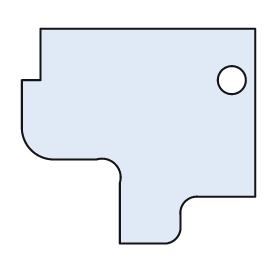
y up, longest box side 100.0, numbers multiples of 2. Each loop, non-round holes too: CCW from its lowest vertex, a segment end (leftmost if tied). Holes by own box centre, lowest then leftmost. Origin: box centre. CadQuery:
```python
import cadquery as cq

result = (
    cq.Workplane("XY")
    .moveTo(-8.0, -46.0)
    .lineTo(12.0, -46.0)
    .threePointArc((16.0, -44.0), (18.0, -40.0))
    .lineTo(18.0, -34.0)
    .threePointArc((20.0, -28.0), (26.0, -26.0))
    .lineTo(50.0, -26.0)
    .lineTo(50.0, 46.0)
    .lineTo(-42.0, 46.0)
    .lineTo(-42.0, 24.0)
    .lineTo(-50.0, 24.0)
    .lineTo(-50.0, 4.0)
    .threePointArc((-46.0, -6.0), (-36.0, -10.0))
    .lineTo(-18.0, -10.0)
    .threePointArc((-10.0, -12.0), (-8.0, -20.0))
    .close()
    .moveTo(40.0, 24.0)
    .circle(6.0)
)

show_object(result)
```